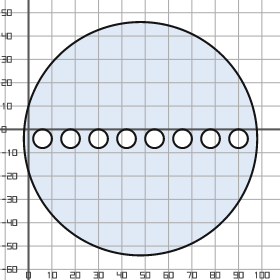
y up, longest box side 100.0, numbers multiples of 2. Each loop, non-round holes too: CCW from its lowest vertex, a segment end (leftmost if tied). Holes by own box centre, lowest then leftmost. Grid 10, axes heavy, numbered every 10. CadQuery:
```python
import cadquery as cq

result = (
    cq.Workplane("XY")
    .moveTo(48.0, -4.0)
    .circle(50.0)
    .moveTo(6.0, -4.0)
    .circle(4.0)
    .moveTo(18.0, -4.0)
    .circle(4.0)
    .moveTo(30.0, -4.0)
    .circle(4.0)
    .moveTo(42.0, -4.0)
    .circle(4.0)
    .moveTo(54.0, -4.0)
    .circle(4.0)
    .moveTo(66.0, -4.0)
    .circle(4.0)
    .moveTo(78.0, -4.0)
    .circle(4.0)
    .moveTo(90.0, -4.0)
    .circle(4.0)
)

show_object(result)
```